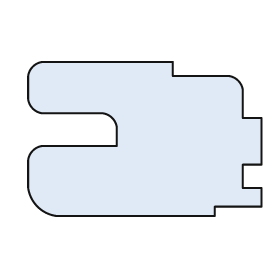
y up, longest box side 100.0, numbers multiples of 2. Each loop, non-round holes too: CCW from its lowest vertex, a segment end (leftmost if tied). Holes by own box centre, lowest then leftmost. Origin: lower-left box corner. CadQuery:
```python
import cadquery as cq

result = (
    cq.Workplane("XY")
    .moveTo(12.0, 0.0)
    .lineTo(80.0, 0.0)
    .lineTo(80.0, 4.0)
    .lineTo(100.0, 4.0)
    .lineTo(100.0, 12.0)
    .lineTo(92.0, 12.0)
    .lineTo(92.0, 22.0)
    .lineTo(100.0, 22.0)
    .lineTo(100.0, 42.0)
    .lineTo(92.0, 42.0)
    .lineTo(92.0, 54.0)
    .threePointArc((90.0, 58.0), (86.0, 60.0))
    .lineTo(62.0, 60.0)
    .lineTo(62.0, 66.0)
    .lineTo(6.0, 66.0)
    .threePointArc((2.0, 64.0), (0.0, 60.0))
    .lineTo(0.0, 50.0)
    .threePointArc((2.0, 46.0), (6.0, 44.0))
    .lineTo(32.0, 44.0)
    .threePointArc((36.0, 42.0), (38.0, 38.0))
    .lineTo(38.0, 30.0)
    .lineTo(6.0, 30.0)
    .threePointArc((2.0, 28.0), (0.0, 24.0))
    .lineTo(0.0, 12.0)
    .threePointArc((4.0, 4.0), (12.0, 0.0))
    .close()
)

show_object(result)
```